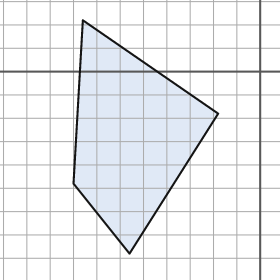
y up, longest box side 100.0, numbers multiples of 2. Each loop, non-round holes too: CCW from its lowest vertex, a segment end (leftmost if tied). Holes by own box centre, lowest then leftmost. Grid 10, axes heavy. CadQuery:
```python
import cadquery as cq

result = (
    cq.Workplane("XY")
    .moveTo(-56.0, -78.0)
    .lineTo(-18.0, -18.0)
    .lineTo(-76.0, 22.0)
    .lineTo(-80.0, -48.0)
    .close()
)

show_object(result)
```